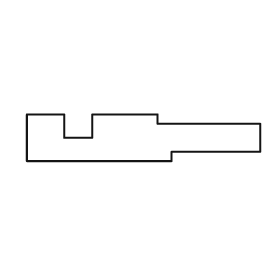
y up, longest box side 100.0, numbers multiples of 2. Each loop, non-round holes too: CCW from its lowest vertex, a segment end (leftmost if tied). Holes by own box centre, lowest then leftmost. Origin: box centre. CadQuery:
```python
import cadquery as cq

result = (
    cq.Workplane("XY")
    .moveTo(-50.0, -10.0)
    .lineTo(12.0, -10.0)
    .lineTo(12.0, -6.0)
    .lineTo(50.0, -6.0)
    .lineTo(50.0, 6.0)
    .lineTo(6.0, 6.0)
    .lineTo(6.0, 10.0)
    .lineTo(-22.0, 10.0)
    .lineTo(-22.0, 0.0)
    .lineTo(-34.0, 0.0)
    .lineTo(-34.0, 10.0)
    .lineTo(-50.0, 10.0)
    .close()
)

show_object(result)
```